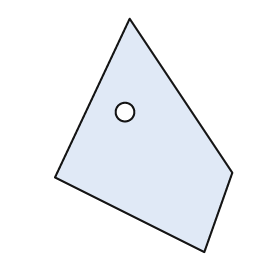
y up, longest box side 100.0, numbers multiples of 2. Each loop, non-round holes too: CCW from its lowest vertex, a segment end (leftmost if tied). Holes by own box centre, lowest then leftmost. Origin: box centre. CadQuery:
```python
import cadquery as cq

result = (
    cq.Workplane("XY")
    .moveTo(26.0, -50.0)
    .lineTo(38.0, -16.0)
    .lineTo(-6.0, 50.0)
    .lineTo(-38.0, -18.0)
    .close()
    .moveTo(-8.0, 10.0)
    .circle(4.0)
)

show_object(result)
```